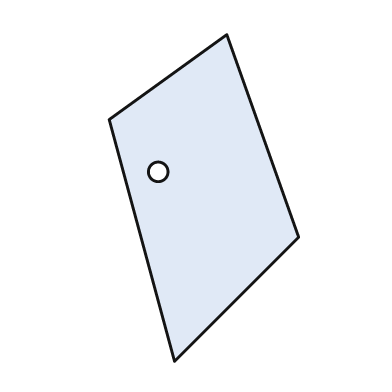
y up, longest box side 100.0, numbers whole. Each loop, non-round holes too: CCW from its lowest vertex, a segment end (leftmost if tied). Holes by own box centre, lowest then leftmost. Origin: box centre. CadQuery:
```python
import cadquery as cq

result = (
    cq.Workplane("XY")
    .moveTo(-9.0, -50.0)
    .lineTo(29.0, -12.0)
    .lineTo(7.0, 50.0)
    .lineTo(-29.0, 24.0)
    .close()
    .moveTo(-14.0, 8.0)
    .circle(3.0)
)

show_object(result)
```